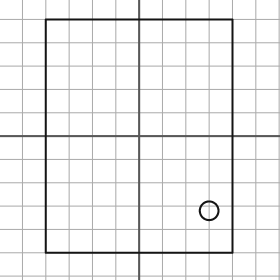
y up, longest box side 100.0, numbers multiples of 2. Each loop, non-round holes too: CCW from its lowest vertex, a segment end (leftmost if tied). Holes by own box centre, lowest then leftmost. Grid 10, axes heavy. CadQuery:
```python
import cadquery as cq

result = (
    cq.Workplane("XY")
    .moveTo(-40.0, -50.0)
    .lineTo(40.0, -50.0)
    .lineTo(40.0, 50.0)
    .lineTo(-40.0, 50.0)
    .close()
    .moveTo(30.0, -32.0)
    .circle(4.0)
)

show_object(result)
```